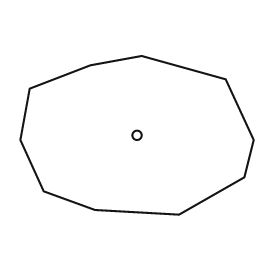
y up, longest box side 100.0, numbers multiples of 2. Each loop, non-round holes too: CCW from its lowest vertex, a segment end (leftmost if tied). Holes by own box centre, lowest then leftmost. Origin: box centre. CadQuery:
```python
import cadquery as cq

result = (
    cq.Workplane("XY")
    .moveTo(18.0, -34.0)
    .lineTo(46.0, -18.0)
    .lineTo(50.0, -2.0)
    .lineTo(38.0, 24.0)
    .lineTo(2.0, 34.0)
    .lineTo(-20.0, 30.0)
    .lineTo(-46.0, 20.0)
    .lineTo(-50.0, -2.0)
    .lineTo(-40.0, -24.0)
    .lineTo(-18.0, -32.0)
    .close()
    .moveTo(0.0, 0.0)
    .circle(2.0)
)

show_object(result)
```